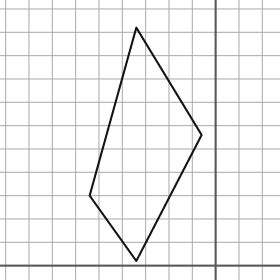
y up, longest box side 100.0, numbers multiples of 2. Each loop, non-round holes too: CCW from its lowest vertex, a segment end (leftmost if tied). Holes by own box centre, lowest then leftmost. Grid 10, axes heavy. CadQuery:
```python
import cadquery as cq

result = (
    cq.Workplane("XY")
    .moveTo(-34.0, 2.0)
    .lineTo(-6.0, 56.0)
    .lineTo(-34.0, 102.0)
    .lineTo(-54.0, 30.0)
    .close()
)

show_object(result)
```